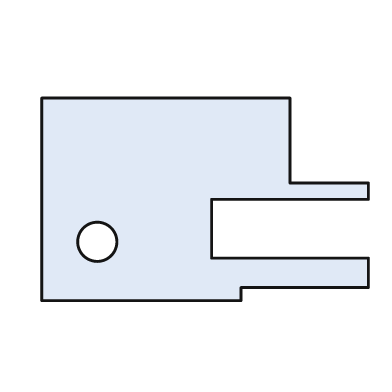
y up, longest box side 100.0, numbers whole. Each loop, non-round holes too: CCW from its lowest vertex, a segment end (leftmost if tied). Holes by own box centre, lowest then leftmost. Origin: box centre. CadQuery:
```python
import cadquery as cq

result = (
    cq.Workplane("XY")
    .moveTo(-50.0, -31.0)
    .lineTo(11.0, -31.0)
    .lineTo(11.0, -27.0)
    .lineTo(50.0, -27.0)
    .lineTo(50.0, -18.0)
    .lineTo(2.0, -18.0)
    .lineTo(2.0, 0.0)
    .lineTo(50.0, 0.0)
    .lineTo(50.0, 5.0)
    .lineTo(26.0, 5.0)
    .lineTo(26.0, 31.0)
    .lineTo(-50.0, 31.0)
    .close()
    .moveTo(-33.0, -13.0)
    .circle(6.0)
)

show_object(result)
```